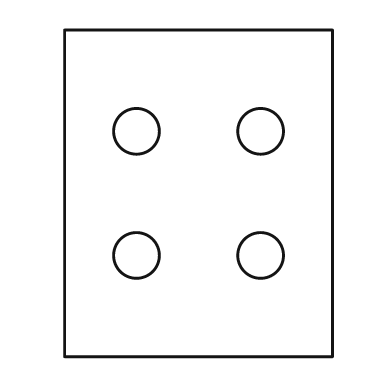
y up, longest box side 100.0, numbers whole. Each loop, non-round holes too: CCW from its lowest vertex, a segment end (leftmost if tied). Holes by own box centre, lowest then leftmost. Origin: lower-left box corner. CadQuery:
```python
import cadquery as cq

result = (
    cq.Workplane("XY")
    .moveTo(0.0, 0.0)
    .lineTo(82.0, 0.0)
    .lineTo(82.0, 100.0)
    .lineTo(0.0, 100.0)
    .close()
    .moveTo(22.0, 31.0)
    .circle(7.0)
    .moveTo(60.0, 31.0)
    .circle(7.0)
    .moveTo(22.0, 69.0)
    .circle(7.0)
    .moveTo(60.0, 69.0)
    .circle(7.0)
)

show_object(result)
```